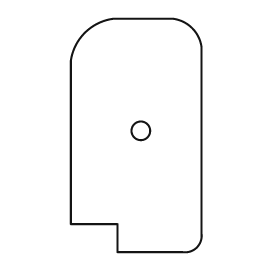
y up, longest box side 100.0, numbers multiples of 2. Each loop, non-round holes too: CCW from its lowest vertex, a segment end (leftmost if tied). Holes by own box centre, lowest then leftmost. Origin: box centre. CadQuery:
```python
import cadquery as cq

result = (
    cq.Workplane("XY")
    .moveTo(-8.0, -50.0)
    .lineTo(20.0, -50.0)
    .threePointArc((26.0, -48.0), (28.0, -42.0))
    .lineTo(28.0, 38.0)
    .threePointArc((24.0, 46.0), (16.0, 50.0))
    .lineTo(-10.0, 50.0)
    .threePointArc((-22.0, 44.0), (-28.0, 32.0))
    .lineTo(-28.0, -38.0)
    .lineTo(-8.0, -38.0)
    .close()
    .moveTo(2.0, 2.0)
    .circle(4.0)
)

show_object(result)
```